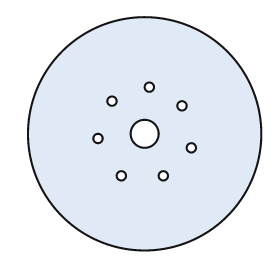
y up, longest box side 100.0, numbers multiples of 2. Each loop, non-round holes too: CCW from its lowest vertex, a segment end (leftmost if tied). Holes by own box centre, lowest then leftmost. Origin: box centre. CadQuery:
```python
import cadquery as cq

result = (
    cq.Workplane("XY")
    .moveTo(0.0, 0.0)
    .circle(50.0)
    .moveTo(-10.0, -18.0)
    .circle(2.0)
    .moveTo(8.0, -18.0)
    .circle(2.0)
    .moveTo(20.0, -6.0)
    .circle(2.0)
    .moveTo(-20.0, -2.0)
    .circle(2.0)
    .moveTo(0.0, 0.0)
    .circle(6.0)
    .moveTo(16.0, 12.0)
    .circle(2.0)
    .moveTo(-14.0, 14.0)
    .circle(2.0)
    .moveTo(2.0, 20.0)
    .circle(2.0)
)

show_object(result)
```